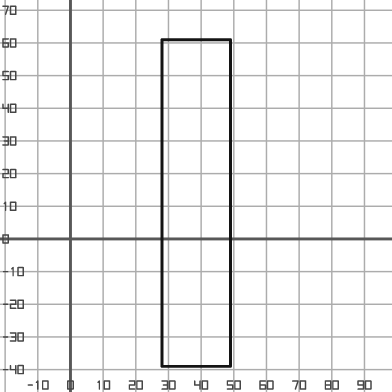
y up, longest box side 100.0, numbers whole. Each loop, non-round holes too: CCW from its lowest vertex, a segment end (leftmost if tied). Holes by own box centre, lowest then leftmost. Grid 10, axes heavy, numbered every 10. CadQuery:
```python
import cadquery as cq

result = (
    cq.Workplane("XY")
    .moveTo(28.0, -39.0)
    .lineTo(49.0, -39.0)
    .lineTo(49.0, 61.0)
    .lineTo(28.0, 61.0)
    .close()
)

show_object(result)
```